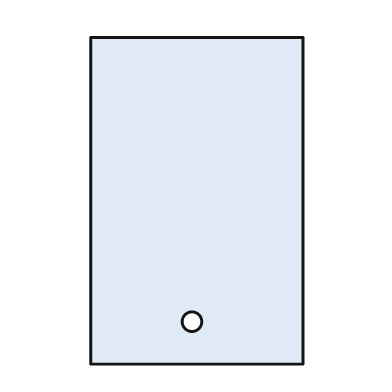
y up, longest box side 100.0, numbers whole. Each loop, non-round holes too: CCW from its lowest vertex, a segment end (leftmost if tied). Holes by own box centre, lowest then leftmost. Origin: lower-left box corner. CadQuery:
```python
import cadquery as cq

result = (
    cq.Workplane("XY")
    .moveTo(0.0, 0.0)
    .lineTo(65.0, 0.0)
    .lineTo(65.0, 100.0)
    .lineTo(0.0, 100.0)
    .close()
    .moveTo(31.0, 13.0)
    .circle(3.0)
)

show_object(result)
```